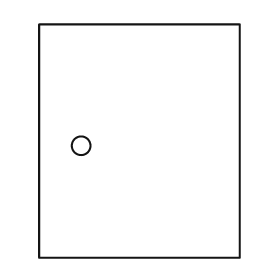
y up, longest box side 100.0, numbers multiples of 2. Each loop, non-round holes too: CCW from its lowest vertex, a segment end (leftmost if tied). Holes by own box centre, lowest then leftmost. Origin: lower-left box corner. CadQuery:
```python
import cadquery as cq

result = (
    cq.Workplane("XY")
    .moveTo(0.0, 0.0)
    .lineTo(86.0, 0.0)
    .lineTo(86.0, 100.0)
    .lineTo(0.0, 100.0)
    .close()
    .moveTo(18.0, 48.0)
    .circle(4.0)
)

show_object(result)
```